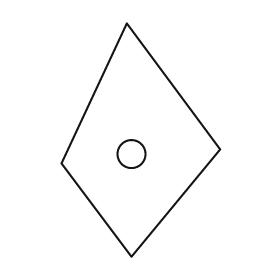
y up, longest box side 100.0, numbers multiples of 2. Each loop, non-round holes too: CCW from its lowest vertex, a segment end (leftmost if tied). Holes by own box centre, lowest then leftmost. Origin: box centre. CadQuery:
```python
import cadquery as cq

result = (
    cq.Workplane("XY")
    .moveTo(-4.0, -50.0)
    .lineTo(34.0, -4.0)
    .lineTo(-6.0, 50.0)
    .lineTo(-34.0, -10.0)
    .close()
    .moveTo(-4.0, -6.0)
    .circle(6.0)
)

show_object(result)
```